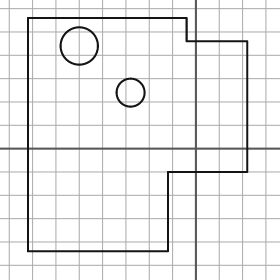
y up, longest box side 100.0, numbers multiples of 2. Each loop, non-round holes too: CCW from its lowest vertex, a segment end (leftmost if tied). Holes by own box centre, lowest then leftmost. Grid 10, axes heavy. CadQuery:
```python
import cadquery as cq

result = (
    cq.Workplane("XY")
    .moveTo(-72.0, -44.0)
    .lineTo(-12.0, -44.0)
    .lineTo(-12.0, -10.0)
    .lineTo(22.0, -10.0)
    .lineTo(22.0, 46.0)
    .lineTo(-4.0, 46.0)
    .lineTo(-4.0, 56.0)
    .lineTo(-72.0, 56.0)
    .close()
    .moveTo(-28.0, 24.0)
    .circle(6.0)
    .moveTo(-50.0, 44.0)
    .circle(8.0)
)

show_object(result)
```